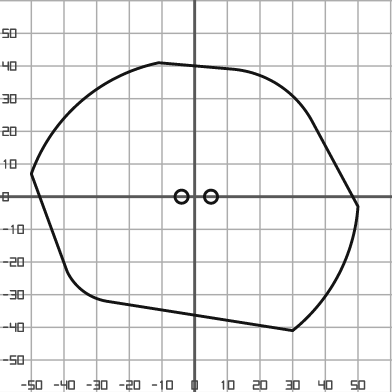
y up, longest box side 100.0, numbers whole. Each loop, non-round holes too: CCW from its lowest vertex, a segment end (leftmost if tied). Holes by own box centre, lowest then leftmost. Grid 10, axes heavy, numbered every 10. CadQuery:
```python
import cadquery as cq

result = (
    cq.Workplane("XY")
    .moveTo(30.0, -41.0)
    .threePointArc((44.0, -24.0), (50.0, -3.0))
    .lineTo(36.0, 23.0)
    .threePointArc((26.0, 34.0), (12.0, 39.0))
    .lineTo(-11.0, 41.0)
    .threePointArc((-35.0, 29.0), (-50.0, 7.0))
    .lineTo(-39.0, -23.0)
    .threePointArc((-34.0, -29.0), (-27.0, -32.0))
    .close()
    .moveTo(-4.0, 0.0)
    .circle(2.0)
    .moveTo(5.0, 0.0)
    .circle(2.0)
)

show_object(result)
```